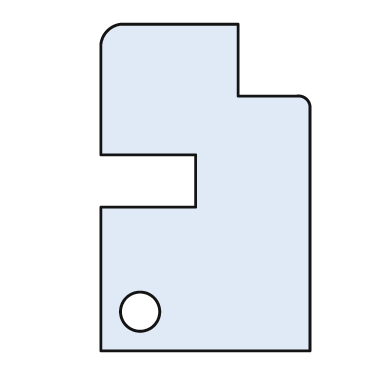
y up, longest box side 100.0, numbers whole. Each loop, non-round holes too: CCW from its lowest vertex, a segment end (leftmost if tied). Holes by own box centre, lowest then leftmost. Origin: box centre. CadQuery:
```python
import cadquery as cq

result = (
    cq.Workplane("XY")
    .moveTo(-32.0, -50.0)
    .lineTo(32.0, -50.0)
    .lineTo(32.0, 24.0)
    .threePointArc((31.0, 27.0), (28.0, 28.0))
    .lineTo(10.0, 28.0)
    .lineTo(10.0, 50.0)
    .lineTo(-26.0, 50.0)
    .threePointArc((-30.0, 48.0), (-32.0, 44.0))
    .lineTo(-32.0, 10.0)
    .lineTo(-3.0, 10.0)
    .lineTo(-3.0, -6.0)
    .lineTo(-32.0, -6.0)
    .close()
    .moveTo(-20.0, -38.0)
    .circle(6.0)
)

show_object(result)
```